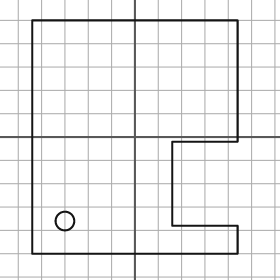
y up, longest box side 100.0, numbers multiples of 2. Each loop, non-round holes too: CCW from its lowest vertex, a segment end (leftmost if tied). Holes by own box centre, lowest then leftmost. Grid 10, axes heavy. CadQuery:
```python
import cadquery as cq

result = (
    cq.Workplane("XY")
    .moveTo(-44.0, -50.0)
    .lineTo(44.0, -50.0)
    .lineTo(44.0, -38.0)
    .lineTo(16.0, -38.0)
    .lineTo(16.0, -2.0)
    .lineTo(44.0, -2.0)
    .lineTo(44.0, 50.0)
    .lineTo(-44.0, 50.0)
    .close()
    .moveTo(-30.0, -36.0)
    .circle(4.0)
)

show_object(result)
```